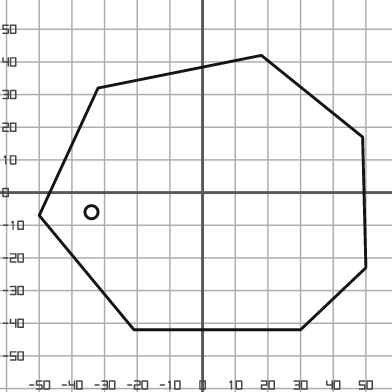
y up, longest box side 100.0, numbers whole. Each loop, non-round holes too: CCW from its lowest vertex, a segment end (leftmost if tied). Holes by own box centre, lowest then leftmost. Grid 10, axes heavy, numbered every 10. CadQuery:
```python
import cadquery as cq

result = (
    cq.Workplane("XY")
    .moveTo(-21.0, -42.0)
    .lineTo(30.0, -42.0)
    .lineTo(50.0, -23.0)
    .lineTo(49.0, 17.0)
    .lineTo(18.0, 42.0)
    .lineTo(-32.0, 32.0)
    .lineTo(-50.0, -7.0)
    .close()
    .moveTo(-34.0, -6.0)
    .circle(2.0)
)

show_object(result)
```